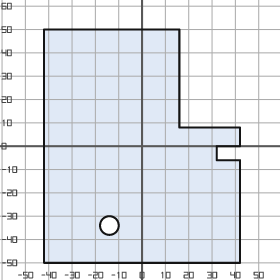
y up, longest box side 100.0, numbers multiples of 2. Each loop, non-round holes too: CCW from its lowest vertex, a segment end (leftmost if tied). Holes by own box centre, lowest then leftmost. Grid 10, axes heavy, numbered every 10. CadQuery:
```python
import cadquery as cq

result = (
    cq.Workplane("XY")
    .moveTo(-42.0, -50.0)
    .lineTo(42.0, -50.0)
    .lineTo(42.0, -6.0)
    .lineTo(32.0, -6.0)
    .lineTo(32.0, 0.0)
    .lineTo(42.0, 0.0)
    .lineTo(42.0, 8.0)
    .lineTo(16.0, 8.0)
    .lineTo(16.0, 50.0)
    .lineTo(-42.0, 50.0)
    .close()
    .moveTo(-14.0, -34.0)
    .circle(4.0)
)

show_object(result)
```